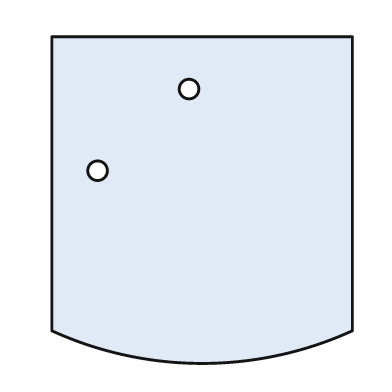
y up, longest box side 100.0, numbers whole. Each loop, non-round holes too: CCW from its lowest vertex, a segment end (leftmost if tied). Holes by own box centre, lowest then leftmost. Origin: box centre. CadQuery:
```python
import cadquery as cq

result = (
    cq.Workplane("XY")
    .moveTo(-46.0, -40.0)
    .threePointArc((0.0, -50.0), (46.0, -40.0))
    .lineTo(46.0, 50.0)
    .lineTo(-46.0, 50.0)
    .close()
    .moveTo(-32.0, 9.0)
    .circle(3.0)
    .moveTo(-4.0, 34.0)
    .circle(3.0)
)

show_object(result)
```